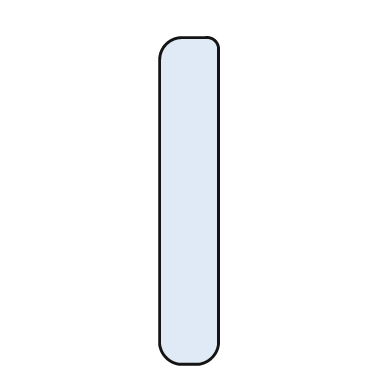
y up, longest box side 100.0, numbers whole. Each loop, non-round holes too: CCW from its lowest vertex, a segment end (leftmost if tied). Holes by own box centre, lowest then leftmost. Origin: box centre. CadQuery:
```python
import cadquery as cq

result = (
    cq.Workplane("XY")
    .moveTo(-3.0, -50.0)
    .lineTo(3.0, -50.0)
    .threePointArc((7.0, -48.0), (9.0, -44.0))
    .lineTo(9.0, 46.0)
    .threePointArc((8.0, 49.0), (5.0, 50.0))
    .lineTo(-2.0, 50.0)
    .threePointArc((-7.0, 48.0), (-9.0, 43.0))
    .lineTo(-9.0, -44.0)
    .threePointArc((-7.0, -48.0), (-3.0, -50.0))
    .close()
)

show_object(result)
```